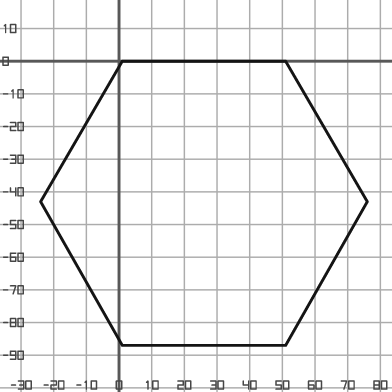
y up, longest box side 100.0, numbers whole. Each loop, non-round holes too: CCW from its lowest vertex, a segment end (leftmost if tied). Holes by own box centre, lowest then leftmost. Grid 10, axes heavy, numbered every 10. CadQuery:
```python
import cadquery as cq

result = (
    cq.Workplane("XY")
    .moveTo(1.0, -87.0)
    .lineTo(51.0, -87.0)
    .lineTo(76.0, -43.0)
    .lineTo(51.0, 0.0)
    .lineTo(1.0, 0.0)
    .lineTo(-24.0, -43.0)
    .close()
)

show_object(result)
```